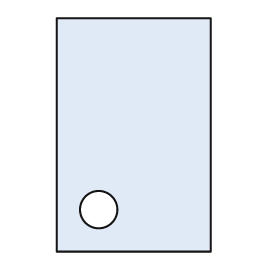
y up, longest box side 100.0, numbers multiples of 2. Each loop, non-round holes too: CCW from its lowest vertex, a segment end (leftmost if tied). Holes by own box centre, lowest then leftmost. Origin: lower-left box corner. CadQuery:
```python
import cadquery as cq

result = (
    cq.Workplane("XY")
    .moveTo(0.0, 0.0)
    .lineTo(66.0, 0.0)
    .lineTo(66.0, 100.0)
    .lineTo(0.0, 100.0)
    .close()
    .moveTo(18.0, 18.0)
    .circle(8.0)
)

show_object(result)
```